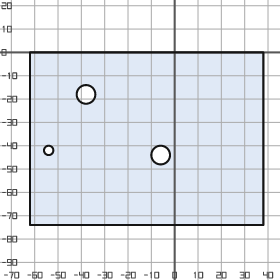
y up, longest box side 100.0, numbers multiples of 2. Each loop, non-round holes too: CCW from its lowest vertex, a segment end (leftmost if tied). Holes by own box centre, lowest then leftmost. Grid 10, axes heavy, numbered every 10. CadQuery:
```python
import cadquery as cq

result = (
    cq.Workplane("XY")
    .moveTo(-62.0, -74.0)
    .lineTo(38.0, -74.0)
    .lineTo(38.0, 0.0)
    .lineTo(-62.0, 0.0)
    .close()
    .moveTo(-6.0, -44.0)
    .circle(4.0)
    .moveTo(-54.0, -42.0)
    .circle(2.0)
    .moveTo(-38.0, -18.0)
    .circle(4.0)
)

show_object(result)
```